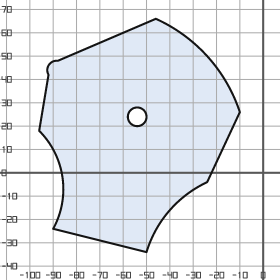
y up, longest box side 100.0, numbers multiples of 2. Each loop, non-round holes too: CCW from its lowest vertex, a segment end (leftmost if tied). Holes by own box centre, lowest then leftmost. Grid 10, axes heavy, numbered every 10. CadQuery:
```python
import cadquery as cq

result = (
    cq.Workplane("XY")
    .moveTo(-50.0, -34.0)
    .threePointArc((-40.0, -16.0), (-24.0, -4.0))
    .lineTo(-10.0, 26.0)
    .threePointArc((-24.0, 50.0), (-46.0, 66.0))
    .lineTo(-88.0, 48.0)
    .threePointArc((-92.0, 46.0), (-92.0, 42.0))
    .lineTo(-96.0, 18.0)
    .threePointArc((-86.0, -2.0), (-90.0, -24.0))
    .close()
    .moveTo(-54.0, 24.0)
    .circle(4.0)
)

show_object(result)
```